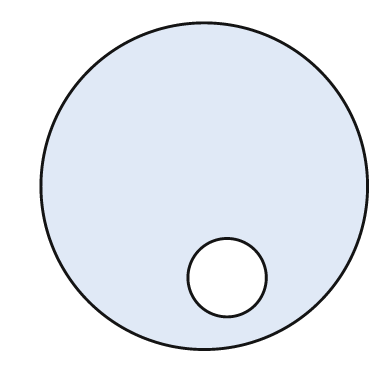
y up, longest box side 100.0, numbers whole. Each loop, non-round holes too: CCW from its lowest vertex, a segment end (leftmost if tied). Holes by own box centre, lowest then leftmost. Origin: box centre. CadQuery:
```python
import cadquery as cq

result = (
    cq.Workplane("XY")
    .moveTo(0.0, 0.0)
    .circle(50.0)
    .moveTo(7.0, -28.0)
    .circle(12.0)
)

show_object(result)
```